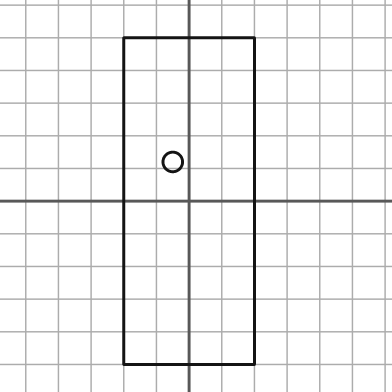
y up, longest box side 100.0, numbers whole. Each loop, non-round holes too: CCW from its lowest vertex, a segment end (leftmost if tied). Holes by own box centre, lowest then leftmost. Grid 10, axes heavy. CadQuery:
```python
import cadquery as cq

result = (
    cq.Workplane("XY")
    .moveTo(-20.0, -50.0)
    .lineTo(20.0, -50.0)
    .lineTo(20.0, 50.0)
    .lineTo(-20.0, 50.0)
    .close()
    .moveTo(-5.0, 12.0)
    .circle(3.0)
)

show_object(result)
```